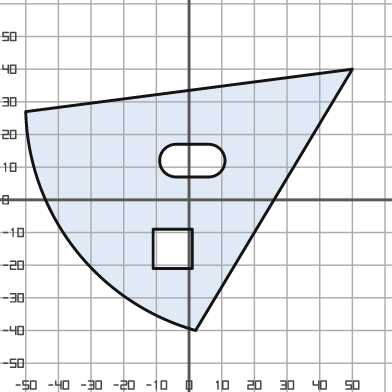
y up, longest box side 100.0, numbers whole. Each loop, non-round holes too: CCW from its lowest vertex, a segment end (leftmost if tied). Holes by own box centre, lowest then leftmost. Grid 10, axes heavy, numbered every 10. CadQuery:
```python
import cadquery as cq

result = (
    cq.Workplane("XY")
    .moveTo(2.0, -40.0)
    .lineTo(50.0, 40.0)
    .lineTo(-50.0, 27.0)
    .threePointArc((-35.0, -15.0), (2.0, -40.0))
    .close()
    .moveTo(-11.0, -21.0)
    .lineTo(1.0, -21.0)
    .lineTo(1.0, -9.0)
    .lineTo(-11.0, -9.0)
    .close()
    .moveTo(-4.0, 7.0)
    .lineTo(6.0, 7.0)
    .threePointArc((11.0, 12.0), (6.0, 17.0))
    .lineTo(-4.0, 17.0)
    .threePointArc((-9.0, 12.0), (-4.0, 7.0))
    .close()
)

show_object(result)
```